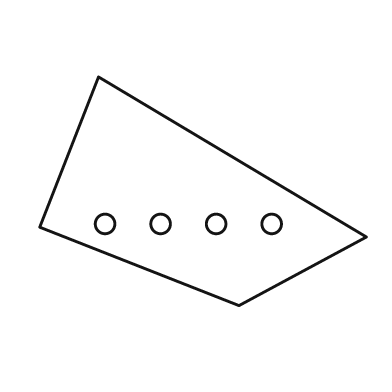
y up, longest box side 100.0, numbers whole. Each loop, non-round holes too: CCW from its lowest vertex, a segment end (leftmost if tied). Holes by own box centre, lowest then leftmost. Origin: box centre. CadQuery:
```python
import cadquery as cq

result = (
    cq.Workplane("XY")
    .moveTo(11.0, -35.0)
    .lineTo(50.0, -14.0)
    .lineTo(-32.0, 35.0)
    .lineTo(-50.0, -11.0)
    .close()
    .moveTo(-30.0, -10.0)
    .circle(3.0)
    .moveTo(-13.0, -10.0)
    .circle(3.0)
    .moveTo(4.0, -10.0)
    .circle(3.0)
    .moveTo(21.0, -10.0)
    .circle(3.0)
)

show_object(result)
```